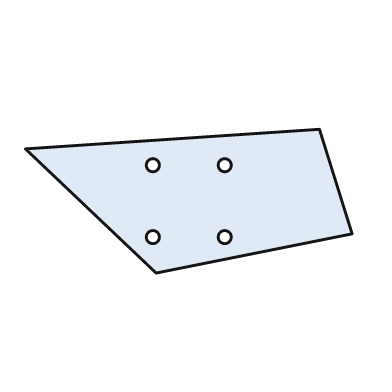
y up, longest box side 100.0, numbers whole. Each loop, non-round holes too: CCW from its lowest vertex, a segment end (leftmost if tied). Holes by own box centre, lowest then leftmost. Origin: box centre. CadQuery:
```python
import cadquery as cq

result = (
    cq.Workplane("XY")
    .moveTo(-10.0, -22.0)
    .lineTo(50.0, -10.0)
    .lineTo(40.0, 22.0)
    .lineTo(-50.0, 16.0)
    .close()
    .moveTo(-11.0, -11.0)
    .circle(2.0)
    .moveTo(11.0, -11.0)
    .circle(2.0)
    .moveTo(-11.0, 11.0)
    .circle(2.0)
    .moveTo(11.0, 11.0)
    .circle(2.0)
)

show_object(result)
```